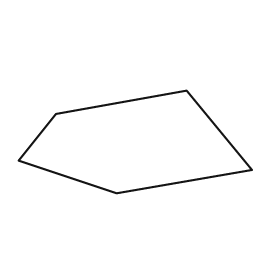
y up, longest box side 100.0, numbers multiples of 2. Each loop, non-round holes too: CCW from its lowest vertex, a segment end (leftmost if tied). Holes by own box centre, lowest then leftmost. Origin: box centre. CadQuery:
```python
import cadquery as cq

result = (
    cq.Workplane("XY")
    .moveTo(-8.0, -22.0)
    .lineTo(50.0, -12.0)
    .lineTo(22.0, 22.0)
    .lineTo(-34.0, 12.0)
    .lineTo(-50.0, -8.0)
    .close()
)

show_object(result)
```